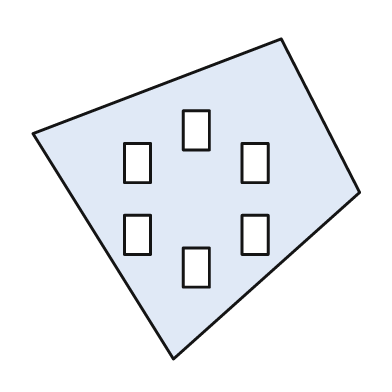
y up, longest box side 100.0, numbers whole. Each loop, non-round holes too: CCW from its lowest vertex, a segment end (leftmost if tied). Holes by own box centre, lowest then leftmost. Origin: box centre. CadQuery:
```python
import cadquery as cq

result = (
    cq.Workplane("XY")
    .moveTo(-7.0, -49.0)
    .lineTo(50.0, 2.0)
    .lineTo(26.0, 49.0)
    .lineTo(-50.0, 20.0)
    .close()
    .moveTo(-4.0, -27.0)
    .lineTo(4.0, -27.0)
    .lineTo(4.0, -15.0)
    .lineTo(-4.0, -15.0)
    .close()
    .moveTo(-22.0, -17.0)
    .lineTo(-14.0, -17.0)
    .lineTo(-14.0, -5.0)
    .lineTo(-22.0, -5.0)
    .close()
    .moveTo(14.0, -17.0)
    .lineTo(22.0, -17.0)
    .lineTo(22.0, -5.0)
    .lineTo(14.0, -5.0)
    .close()
    .moveTo(-22.0, 5.0)
    .lineTo(-14.0, 5.0)
    .lineTo(-14.0, 17.0)
    .lineTo(-22.0, 17.0)
    .close()
    .moveTo(14.0, 5.0)
    .lineTo(22.0, 5.0)
    .lineTo(22.0, 17.0)
    .lineTo(14.0, 17.0)
    .close()
    .moveTo(-4.0, 15.0)
    .lineTo(4.0, 15.0)
    .lineTo(4.0, 27.0)
    .lineTo(-4.0, 27.0)
    .close()
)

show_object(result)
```